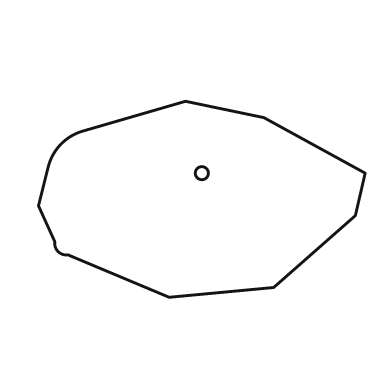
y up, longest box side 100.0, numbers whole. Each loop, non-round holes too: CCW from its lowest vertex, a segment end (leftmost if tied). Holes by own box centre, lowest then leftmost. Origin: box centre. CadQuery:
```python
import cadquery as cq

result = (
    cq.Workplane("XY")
    .moveTo(-10.0, -30.0)
    .lineTo(22.0, -27.0)
    .lineTo(47.0, -5.0)
    .lineTo(50.0, 8.0)
    .lineTo(19.0, 25.0)
    .lineTo(-5.0, 30.0)
    .lineTo(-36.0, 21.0)
    .threePointArc((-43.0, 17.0), (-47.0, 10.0))
    .lineTo(-50.0, -2.0)
    .lineTo(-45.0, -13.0)
    .threePointArc((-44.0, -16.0), (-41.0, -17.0))
    .close()
    .moveTo(0.0, 8.0)
    .circle(2.0)
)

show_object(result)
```